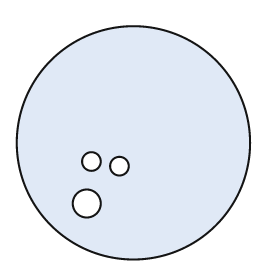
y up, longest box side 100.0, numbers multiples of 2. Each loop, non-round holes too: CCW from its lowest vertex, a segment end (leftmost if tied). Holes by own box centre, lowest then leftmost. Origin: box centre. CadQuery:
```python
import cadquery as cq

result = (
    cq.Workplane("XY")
    .moveTo(0.0, 0.0)
    .circle(50.0)
    .moveTo(-20.0, -26.0)
    .circle(6.0)
    .moveTo(-6.0, -10.0)
    .circle(4.0)
    .moveTo(-18.0, -8.0)
    .circle(4.0)
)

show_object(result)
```